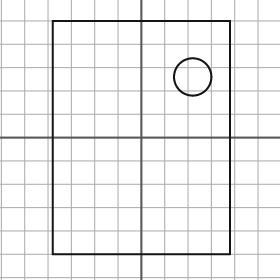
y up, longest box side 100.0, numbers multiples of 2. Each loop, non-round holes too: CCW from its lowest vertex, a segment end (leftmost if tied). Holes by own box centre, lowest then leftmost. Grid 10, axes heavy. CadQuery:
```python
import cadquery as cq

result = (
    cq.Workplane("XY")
    .moveTo(-38.0, -50.0)
    .lineTo(38.0, -50.0)
    .lineTo(38.0, 50.0)
    .lineTo(-38.0, 50.0)
    .close()
    .moveTo(22.0, 26.0)
    .circle(8.0)
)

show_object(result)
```